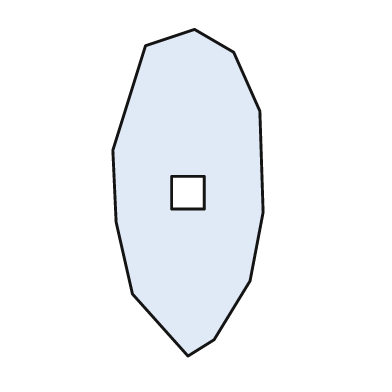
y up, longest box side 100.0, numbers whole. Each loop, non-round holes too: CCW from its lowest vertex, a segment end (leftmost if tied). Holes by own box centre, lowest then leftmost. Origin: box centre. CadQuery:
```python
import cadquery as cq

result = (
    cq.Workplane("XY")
    .moveTo(0.0, -50.0)
    .lineTo(8.0, -45.0)
    .lineTo(19.0, -27.0)
    .lineTo(23.0, -6.0)
    .lineTo(22.0, 25.0)
    .lineTo(14.0, 43.0)
    .lineTo(2.0, 50.0)
    .lineTo(-13.0, 45.0)
    .lineTo(-23.0, 13.0)
    .lineTo(-22.0, -9.0)
    .lineTo(-17.0, -31.0)
    .close()
    .moveTo(-5.0, -5.0)
    .lineTo(5.0, -5.0)
    .lineTo(5.0, 5.0)
    .lineTo(-5.0, 5.0)
    .close()
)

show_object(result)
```